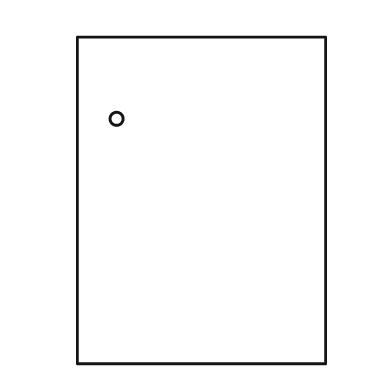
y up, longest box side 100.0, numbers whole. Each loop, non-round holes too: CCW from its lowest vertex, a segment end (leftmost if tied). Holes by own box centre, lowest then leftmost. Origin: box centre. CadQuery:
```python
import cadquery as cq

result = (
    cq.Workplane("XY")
    .moveTo(-38.0, -50.0)
    .lineTo(38.0, -50.0)
    .lineTo(38.0, 50.0)
    .lineTo(-38.0, 50.0)
    .close()
    .moveTo(-26.0, 25.0)
    .circle(2.0)
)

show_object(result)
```